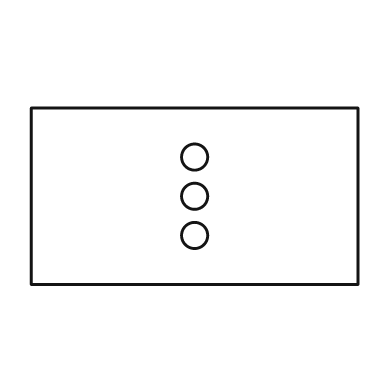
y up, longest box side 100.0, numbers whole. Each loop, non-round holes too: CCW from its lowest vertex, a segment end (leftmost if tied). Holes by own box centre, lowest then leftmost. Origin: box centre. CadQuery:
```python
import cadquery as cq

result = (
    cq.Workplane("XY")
    .moveTo(-50.0, -27.0)
    .lineTo(50.0, -27.0)
    .lineTo(50.0, 27.0)
    .lineTo(-50.0, 27.0)
    .close()
    .moveTo(0.0, -12.0)
    .circle(4.0)
    .moveTo(0.0, 0.0)
    .circle(4.0)
    .moveTo(0.0, 12.0)
    .circle(4.0)
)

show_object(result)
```